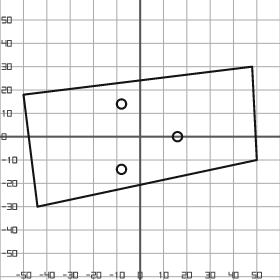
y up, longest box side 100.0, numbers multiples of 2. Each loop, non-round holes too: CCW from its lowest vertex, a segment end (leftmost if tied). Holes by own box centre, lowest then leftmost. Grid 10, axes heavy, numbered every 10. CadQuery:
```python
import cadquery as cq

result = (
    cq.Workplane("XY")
    .moveTo(-44.0, -30.0)
    .lineTo(50.0, -10.0)
    .lineTo(48.0, 30.0)
    .lineTo(-50.0, 18.0)
    .close()
    .moveTo(-8.0, -14.0)
    .circle(2.0)
    .moveTo(16.0, 0.0)
    .circle(2.0)
    .moveTo(-8.0, 14.0)
    .circle(2.0)
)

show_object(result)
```